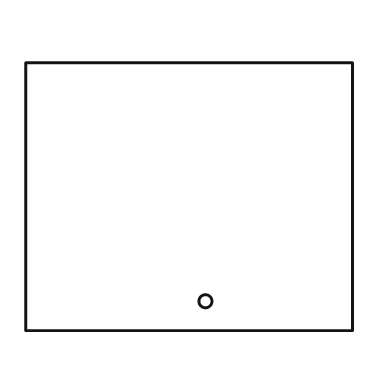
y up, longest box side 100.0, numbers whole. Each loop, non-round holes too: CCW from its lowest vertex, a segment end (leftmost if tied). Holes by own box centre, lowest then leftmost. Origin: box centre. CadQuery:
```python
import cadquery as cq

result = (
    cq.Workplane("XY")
    .moveTo(-50.0, -41.0)
    .lineTo(50.0, -41.0)
    .lineTo(50.0, 41.0)
    .lineTo(-50.0, 41.0)
    .close()
    .moveTo(5.0, -32.0)
    .circle(2.0)
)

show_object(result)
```